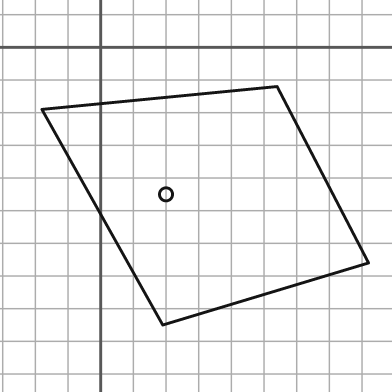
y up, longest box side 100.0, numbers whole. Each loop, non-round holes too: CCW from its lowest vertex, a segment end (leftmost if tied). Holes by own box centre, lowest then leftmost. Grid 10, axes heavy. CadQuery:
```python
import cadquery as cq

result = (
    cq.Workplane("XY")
    .moveTo(19.0, -85.0)
    .lineTo(82.0, -66.0)
    .lineTo(54.0, -12.0)
    .lineTo(-18.0, -19.0)
    .close()
    .moveTo(20.0, -45.0)
    .circle(2.0)
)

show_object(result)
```